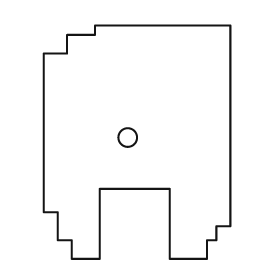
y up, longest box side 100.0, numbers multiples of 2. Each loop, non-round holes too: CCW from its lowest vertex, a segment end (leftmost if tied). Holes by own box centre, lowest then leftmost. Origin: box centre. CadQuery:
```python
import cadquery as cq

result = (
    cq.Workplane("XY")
    .moveTo(-28.0, -50.0)
    .lineTo(-16.0, -50.0)
    .lineTo(-16.0, -20.0)
    .lineTo(14.0, -20.0)
    .lineTo(14.0, -50.0)
    .lineTo(30.0, -50.0)
    .lineTo(30.0, -42.0)
    .lineTo(34.0, -42.0)
    .lineTo(34.0, -36.0)
    .lineTo(40.0, -36.0)
    .lineTo(40.0, 50.0)
    .lineTo(-18.0, 50.0)
    .lineTo(-18.0, 46.0)
    .lineTo(-30.0, 46.0)
    .lineTo(-30.0, 38.0)
    .lineTo(-40.0, 38.0)
    .lineTo(-40.0, -30.0)
    .lineTo(-34.0, -30.0)
    .lineTo(-34.0, -42.0)
    .lineTo(-28.0, -42.0)
    .close()
    .moveTo(-4.0, 2.0)
    .circle(4.0)
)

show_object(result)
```